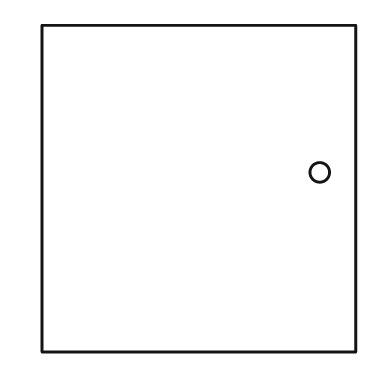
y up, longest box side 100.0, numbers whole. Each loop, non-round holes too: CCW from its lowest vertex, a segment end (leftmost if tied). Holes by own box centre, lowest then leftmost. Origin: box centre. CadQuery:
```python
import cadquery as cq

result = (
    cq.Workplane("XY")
    .moveTo(-48.0, -50.0)
    .lineTo(48.0, -50.0)
    .lineTo(48.0, 50.0)
    .lineTo(-48.0, 50.0)
    .close()
    .moveTo(37.0, 5.0)
    .circle(3.0)
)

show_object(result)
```